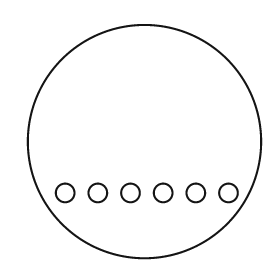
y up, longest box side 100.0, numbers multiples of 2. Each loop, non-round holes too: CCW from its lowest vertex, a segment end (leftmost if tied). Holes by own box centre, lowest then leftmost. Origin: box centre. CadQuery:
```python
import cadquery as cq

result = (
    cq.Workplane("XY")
    .moveTo(0.0, 0.0)
    .circle(50.0)
    .moveTo(-34.0, -22.0)
    .circle(4.0)
    .moveTo(-20.0, -22.0)
    .circle(4.0)
    .moveTo(-6.0, -22.0)
    .circle(4.0)
    .moveTo(8.0, -22.0)
    .circle(4.0)
    .moveTo(22.0, -22.0)
    .circle(4.0)
    .moveTo(36.0, -22.0)
    .circle(4.0)
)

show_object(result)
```